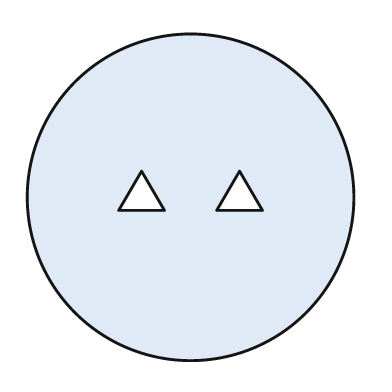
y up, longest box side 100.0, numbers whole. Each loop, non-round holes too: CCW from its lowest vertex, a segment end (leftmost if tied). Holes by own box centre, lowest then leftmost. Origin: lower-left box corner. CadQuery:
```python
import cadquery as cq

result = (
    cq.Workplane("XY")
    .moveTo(50.0, 50.0)
    .circle(50.0)
    .moveTo(28.0, 46.0)
    .lineTo(42.0, 46.0)
    .lineTo(35.0, 58.0)
    .close()
    .moveTo(58.0, 46.0)
    .lineTo(72.0, 46.0)
    .lineTo(65.0, 58.0)
    .close()
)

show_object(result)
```